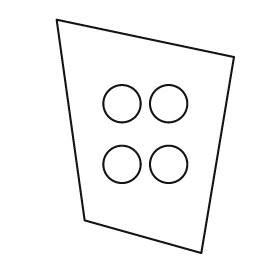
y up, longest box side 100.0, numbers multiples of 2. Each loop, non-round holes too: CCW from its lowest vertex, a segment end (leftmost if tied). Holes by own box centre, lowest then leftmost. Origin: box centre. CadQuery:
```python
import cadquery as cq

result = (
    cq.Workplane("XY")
    .moveTo(24.0, -50.0)
    .lineTo(38.0, 34.0)
    .lineTo(-38.0, 50.0)
    .lineTo(-26.0, -36.0)
    .close()
    .moveTo(-10.0, -12.0)
    .circle(8.0)
    .moveTo(10.0, -12.0)
    .circle(8.0)
    .moveTo(-10.0, 14.0)
    .circle(8.0)
    .moveTo(10.0, 14.0)
    .circle(8.0)
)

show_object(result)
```